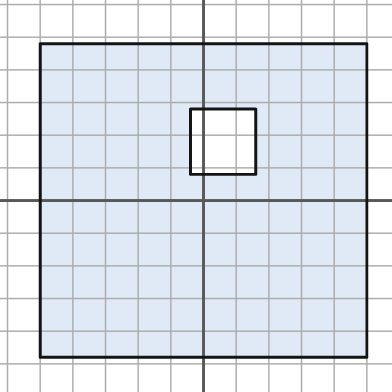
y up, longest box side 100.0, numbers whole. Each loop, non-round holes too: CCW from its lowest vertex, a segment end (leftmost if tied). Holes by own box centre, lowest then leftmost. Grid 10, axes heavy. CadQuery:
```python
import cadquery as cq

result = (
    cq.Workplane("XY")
    .moveTo(-50.0, -48.0)
    .lineTo(50.0, -48.0)
    .lineTo(50.0, 48.0)
    .lineTo(-50.0, 48.0)
    .close()
    .moveTo(-4.0, 8.0)
    .lineTo(16.0, 8.0)
    .lineTo(16.0, 28.0)
    .lineTo(-4.0, 28.0)
    .close()
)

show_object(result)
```